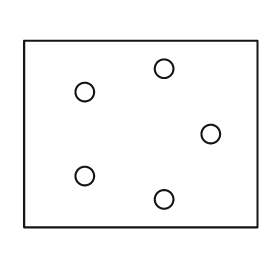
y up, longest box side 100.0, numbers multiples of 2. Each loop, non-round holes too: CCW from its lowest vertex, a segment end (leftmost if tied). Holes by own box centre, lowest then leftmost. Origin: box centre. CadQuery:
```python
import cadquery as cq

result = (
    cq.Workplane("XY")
    .moveTo(-50.0, -40.0)
    .lineTo(50.0, -40.0)
    .lineTo(50.0, 40.0)
    .lineTo(-50.0, 40.0)
    .close()
    .moveTo(10.0, -28.0)
    .circle(4.0)
    .moveTo(-24.0, -18.0)
    .circle(4.0)
    .moveTo(30.0, 0.0)
    .circle(4.0)
    .moveTo(-24.0, 18.0)
    .circle(4.0)
    .moveTo(10.0, 28.0)
    .circle(4.0)
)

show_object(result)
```